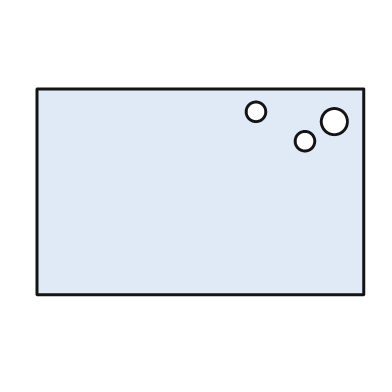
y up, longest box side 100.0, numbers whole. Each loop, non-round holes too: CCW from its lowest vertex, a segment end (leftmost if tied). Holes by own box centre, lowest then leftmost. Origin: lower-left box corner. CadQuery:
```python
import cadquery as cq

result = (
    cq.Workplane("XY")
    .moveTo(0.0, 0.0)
    .lineTo(100.0, 0.0)
    .lineTo(100.0, 63.0)
    .lineTo(0.0, 63.0)
    .close()
    .moveTo(82.0, 47.0)
    .circle(3.0)
    .moveTo(91.0, 53.0)
    .circle(4.0)
    .moveTo(67.0, 56.0)
    .circle(3.0)
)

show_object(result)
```